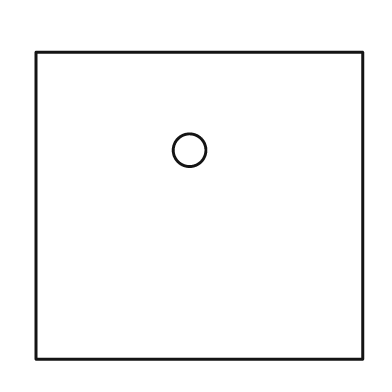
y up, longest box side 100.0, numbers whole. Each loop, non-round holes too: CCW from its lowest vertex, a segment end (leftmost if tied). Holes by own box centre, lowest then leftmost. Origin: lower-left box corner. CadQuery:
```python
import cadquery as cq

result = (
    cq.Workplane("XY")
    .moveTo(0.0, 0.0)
    .lineTo(100.0, 0.0)
    .lineTo(100.0, 94.0)
    .lineTo(0.0, 94.0)
    .close()
    .moveTo(47.0, 64.0)
    .circle(5.0)
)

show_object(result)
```